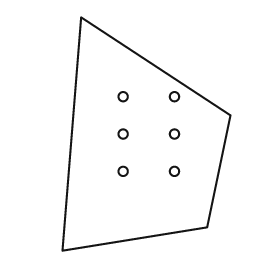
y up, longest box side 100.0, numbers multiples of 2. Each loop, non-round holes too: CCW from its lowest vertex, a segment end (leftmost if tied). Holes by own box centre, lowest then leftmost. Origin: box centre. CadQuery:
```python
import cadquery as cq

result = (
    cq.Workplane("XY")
    .moveTo(-36.0, -50.0)
    .lineTo(26.0, -40.0)
    .lineTo(36.0, 8.0)
    .lineTo(-28.0, 50.0)
    .close()
    .moveTo(-10.0, -16.0)
    .circle(2.0)
    .moveTo(12.0, -16.0)
    .circle(2.0)
    .moveTo(-10.0, 0.0)
    .circle(2.0)
    .moveTo(12.0, 0.0)
    .circle(2.0)
    .moveTo(-10.0, 16.0)
    .circle(2.0)
    .moveTo(12.0, 16.0)
    .circle(2.0)
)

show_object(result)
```